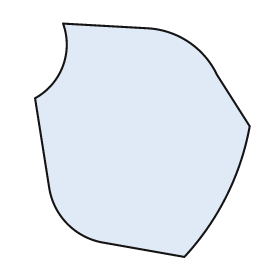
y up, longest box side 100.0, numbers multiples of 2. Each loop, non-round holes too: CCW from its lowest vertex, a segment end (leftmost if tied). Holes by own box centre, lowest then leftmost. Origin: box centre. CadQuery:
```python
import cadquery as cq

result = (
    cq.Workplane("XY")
    .moveTo(18.0, -50.0)
    .threePointArc((36.0, -24.0), (46.0, 6.0))
    .lineTo(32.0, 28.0)
    .threePointArc((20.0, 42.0), (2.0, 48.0))
    .lineTo(-34.0, 50.0)
    .threePointArc((-34.0, 32.0), (-46.0, 18.0))
    .lineTo(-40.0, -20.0)
    .threePointArc((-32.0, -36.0), (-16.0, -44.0))
    .close()
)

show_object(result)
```